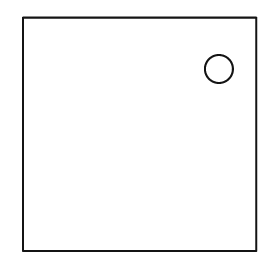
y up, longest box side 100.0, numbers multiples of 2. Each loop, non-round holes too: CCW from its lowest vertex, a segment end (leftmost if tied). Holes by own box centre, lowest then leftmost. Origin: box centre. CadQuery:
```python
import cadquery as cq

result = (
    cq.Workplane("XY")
    .moveTo(-50.0, -50.0)
    .lineTo(50.0, -50.0)
    .lineTo(50.0, 50.0)
    .lineTo(-50.0, 50.0)
    .close()
    .moveTo(34.0, 28.0)
    .circle(6.0)
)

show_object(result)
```